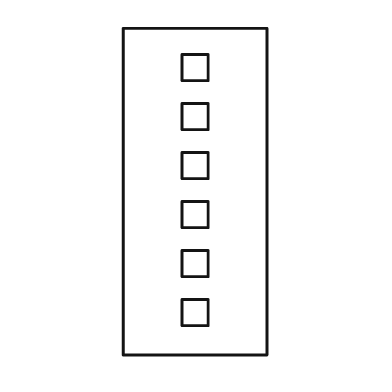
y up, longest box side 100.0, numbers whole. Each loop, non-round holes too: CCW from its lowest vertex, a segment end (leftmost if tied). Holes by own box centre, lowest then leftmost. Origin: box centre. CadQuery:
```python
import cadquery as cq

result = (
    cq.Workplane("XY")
    .moveTo(-22.0, -50.0)
    .lineTo(22.0, -50.0)
    .lineTo(22.0, 50.0)
    .lineTo(-22.0, 50.0)
    .close()
    .moveTo(-4.0, -41.0)
    .lineTo(4.0, -41.0)
    .lineTo(4.0, -33.0)
    .lineTo(-4.0, -33.0)
    .close()
    .moveTo(-4.0, -26.0)
    .lineTo(4.0, -26.0)
    .lineTo(4.0, -18.0)
    .lineTo(-4.0, -18.0)
    .close()
    .moveTo(-4.0, -11.0)
    .lineTo(4.0, -11.0)
    .lineTo(4.0, -3.0)
    .lineTo(-4.0, -3.0)
    .close()
    .moveTo(-4.0, 4.0)
    .lineTo(4.0, 4.0)
    .lineTo(4.0, 12.0)
    .lineTo(-4.0, 12.0)
    .close()
    .moveTo(-4.0, 19.0)
    .lineTo(4.0, 19.0)
    .lineTo(4.0, 27.0)
    .lineTo(-4.0, 27.0)
    .close()
    .moveTo(-4.0, 34.0)
    .lineTo(4.0, 34.0)
    .lineTo(4.0, 42.0)
    .lineTo(-4.0, 42.0)
    .close()
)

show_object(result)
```